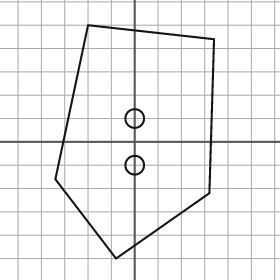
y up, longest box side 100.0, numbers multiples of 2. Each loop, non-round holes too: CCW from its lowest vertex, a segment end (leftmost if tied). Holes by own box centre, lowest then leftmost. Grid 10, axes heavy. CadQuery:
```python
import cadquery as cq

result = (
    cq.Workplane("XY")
    .moveTo(-8.0, -50.0)
    .lineTo(32.0, -22.0)
    .lineTo(34.0, 44.0)
    .lineTo(-20.0, 50.0)
    .lineTo(-34.0, -16.0)
    .close()
    .moveTo(0.0, -10.0)
    .circle(4.0)
    .moveTo(0.0, 10.0)
    .circle(4.0)
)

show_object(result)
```